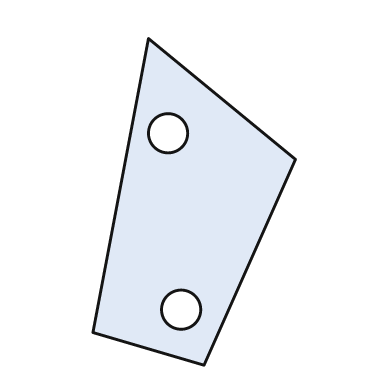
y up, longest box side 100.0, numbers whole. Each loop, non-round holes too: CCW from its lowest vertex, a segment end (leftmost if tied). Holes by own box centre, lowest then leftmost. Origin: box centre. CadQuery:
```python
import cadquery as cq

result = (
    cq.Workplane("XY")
    .moveTo(3.0, -50.0)
    .lineTo(31.0, 13.0)
    .lineTo(-14.0, 50.0)
    .lineTo(-31.0, -40.0)
    .close()
    .moveTo(-4.0, -33.0)
    .circle(6.0)
    .moveTo(-8.0, 21.0)
    .circle(6.0)
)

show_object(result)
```